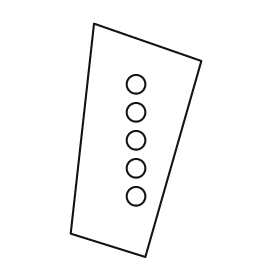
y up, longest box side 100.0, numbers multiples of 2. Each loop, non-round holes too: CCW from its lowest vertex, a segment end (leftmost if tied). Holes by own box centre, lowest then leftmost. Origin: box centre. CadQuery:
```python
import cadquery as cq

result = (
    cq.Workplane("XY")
    .moveTo(4.0, -50.0)
    .lineTo(28.0, 34.0)
    .lineTo(-18.0, 50.0)
    .lineTo(-28.0, -40.0)
    .close()
    .moveTo(0.0, -24.0)
    .circle(4.0)
    .moveTo(0.0, -12.0)
    .circle(4.0)
    .moveTo(0.0, 0.0)
    .circle(4.0)
    .moveTo(0.0, 12.0)
    .circle(4.0)
    .moveTo(0.0, 24.0)
    .circle(4.0)
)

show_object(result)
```